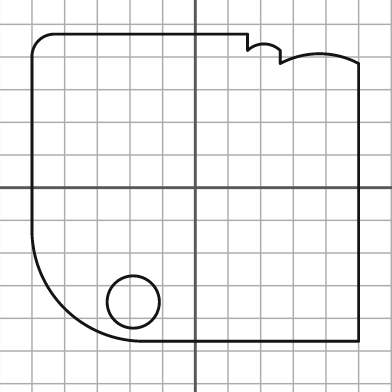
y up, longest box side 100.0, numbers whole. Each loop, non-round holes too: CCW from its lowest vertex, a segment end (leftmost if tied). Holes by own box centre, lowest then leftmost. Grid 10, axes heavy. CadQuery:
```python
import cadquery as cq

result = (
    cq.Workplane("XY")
    .moveTo(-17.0, -47.0)
    .lineTo(50.0, -47.0)
    .lineTo(50.0, 38.0)
    .threePointArc((38.0, 41.0), (26.0, 38.0))
    .lineTo(26.0, 42.0)
    .threePointArc((21.0, 44.0), (16.0, 42.0))
    .lineTo(16.0, 47.0)
    .lineTo(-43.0, 47.0)
    .threePointArc((-48.0, 45.0), (-50.0, 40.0))
    .lineTo(-50.0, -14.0)
    .threePointArc((-40.0, -37.0), (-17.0, -47.0))
    .close()
    .moveTo(-19.0, -35.0)
    .circle(8.0)
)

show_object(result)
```